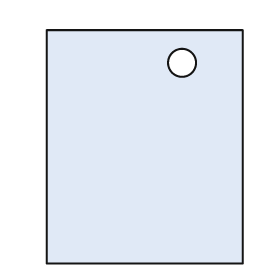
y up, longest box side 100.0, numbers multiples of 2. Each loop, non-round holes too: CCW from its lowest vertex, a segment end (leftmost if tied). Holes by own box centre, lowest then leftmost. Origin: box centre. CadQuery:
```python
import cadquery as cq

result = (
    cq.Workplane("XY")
    .moveTo(-42.0, -50.0)
    .lineTo(42.0, -50.0)
    .lineTo(42.0, 50.0)
    .lineTo(-42.0, 50.0)
    .close()
    .moveTo(16.0, 36.0)
    .circle(6.0)
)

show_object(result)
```